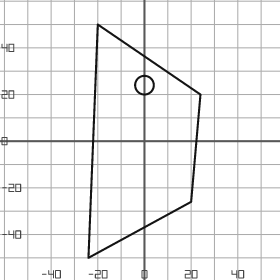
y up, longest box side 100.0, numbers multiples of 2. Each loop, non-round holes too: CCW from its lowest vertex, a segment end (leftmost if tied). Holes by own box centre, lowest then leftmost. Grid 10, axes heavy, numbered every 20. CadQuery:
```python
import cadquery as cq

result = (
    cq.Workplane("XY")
    .moveTo(-24.0, -50.0)
    .lineTo(20.0, -26.0)
    .lineTo(24.0, 20.0)
    .lineTo(-20.0, 50.0)
    .close()
    .moveTo(0.0, 24.0)
    .circle(4.0)
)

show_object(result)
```